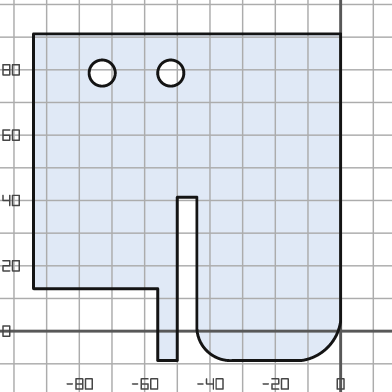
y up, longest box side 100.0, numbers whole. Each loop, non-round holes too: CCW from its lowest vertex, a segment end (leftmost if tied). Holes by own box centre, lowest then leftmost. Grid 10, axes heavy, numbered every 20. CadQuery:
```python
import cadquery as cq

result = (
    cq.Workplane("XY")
    .moveTo(-56.0, -9.0)
    .lineTo(-50.0, -9.0)
    .lineTo(-50.0, 41.0)
    .lineTo(-44.0, 41.0)
    .lineTo(-44.0, 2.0)
    .threePointArc((-41.0, -6.0), (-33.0, -9.0))
    .lineTo(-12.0, -9.0)
    .threePointArc((-4.0, -5.0), (0.0, 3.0))
    .lineTo(0.0, 91.0)
    .lineTo(-94.0, 91.0)
    .lineTo(-94.0, 13.0)
    .lineTo(-56.0, 13.0)
    .close()
    .moveTo(-73.0, 79.0)
    .circle(4.0)
    .moveTo(-52.0, 79.0)
    .circle(4.0)
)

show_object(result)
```